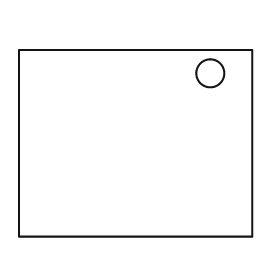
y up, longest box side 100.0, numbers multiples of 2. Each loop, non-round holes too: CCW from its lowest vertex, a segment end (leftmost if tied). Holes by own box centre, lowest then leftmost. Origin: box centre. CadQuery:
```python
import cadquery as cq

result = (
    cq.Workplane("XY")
    .moveTo(-50.0, -40.0)
    .lineTo(50.0, -40.0)
    .lineTo(50.0, 40.0)
    .lineTo(-50.0, 40.0)
    .close()
    .moveTo(32.0, 30.0)
    .circle(6.0)
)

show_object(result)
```